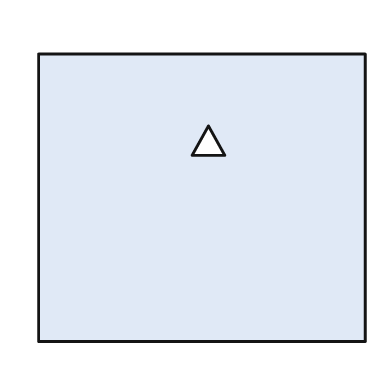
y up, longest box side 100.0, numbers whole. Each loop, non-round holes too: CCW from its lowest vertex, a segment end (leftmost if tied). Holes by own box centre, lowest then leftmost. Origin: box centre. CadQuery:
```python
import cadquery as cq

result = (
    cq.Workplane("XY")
    .moveTo(-50.0, -44.0)
    .lineTo(50.0, -44.0)
    .lineTo(50.0, 44.0)
    .lineTo(-50.0, 44.0)
    .close()
    .moveTo(-3.0, 13.0)
    .lineTo(7.0, 13.0)
    .lineTo(2.0, 22.0)
    .close()
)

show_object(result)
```